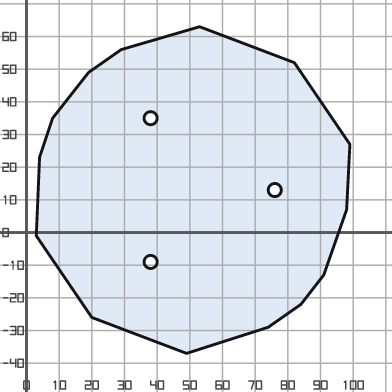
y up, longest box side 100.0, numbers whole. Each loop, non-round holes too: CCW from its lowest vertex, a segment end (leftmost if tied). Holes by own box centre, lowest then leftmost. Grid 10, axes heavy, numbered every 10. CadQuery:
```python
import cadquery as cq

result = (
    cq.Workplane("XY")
    .moveTo(49.0, -37.0)
    .lineTo(74.0, -29.0)
    .lineTo(84.0, -22.0)
    .lineTo(91.0, -13.0)
    .lineTo(98.0, 7.0)
    .lineTo(99.0, 27.0)
    .lineTo(82.0, 52.0)
    .lineTo(53.0, 63.0)
    .lineTo(29.0, 56.0)
    .lineTo(19.0, 49.0)
    .lineTo(8.0, 35.0)
    .lineTo(4.0, 23.0)
    .lineTo(3.0, -1.0)
    .lineTo(20.0, -26.0)
    .close()
    .moveTo(38.0, -9.0)
    .circle(2.0)
    .moveTo(76.0, 13.0)
    .circle(2.0)
    .moveTo(38.0, 35.0)
    .circle(2.0)
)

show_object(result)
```